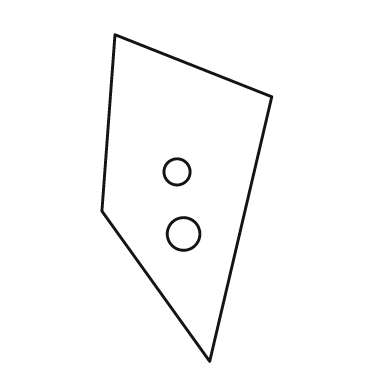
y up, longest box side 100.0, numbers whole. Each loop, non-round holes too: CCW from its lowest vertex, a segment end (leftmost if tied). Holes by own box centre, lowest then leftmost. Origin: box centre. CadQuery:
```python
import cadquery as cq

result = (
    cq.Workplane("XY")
    .moveTo(7.0, -50.0)
    .lineTo(26.0, 31.0)
    .lineTo(-22.0, 50.0)
    .lineTo(-26.0, -4.0)
    .close()
    .moveTo(-1.0, -11.0)
    .circle(5.0)
    .moveTo(-3.0, 8.0)
    .circle(4.0)
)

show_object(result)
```